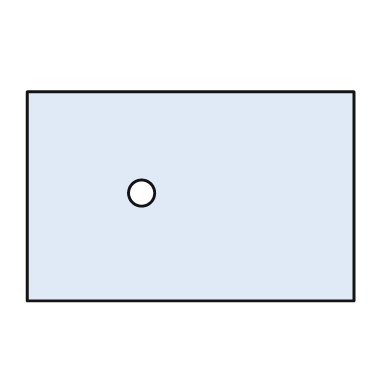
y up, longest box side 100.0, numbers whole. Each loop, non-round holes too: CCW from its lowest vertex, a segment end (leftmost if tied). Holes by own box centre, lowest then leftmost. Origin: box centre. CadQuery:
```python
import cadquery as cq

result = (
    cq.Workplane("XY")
    .moveTo(-50.0, -32.0)
    .lineTo(50.0, -32.0)
    .lineTo(50.0, 32.0)
    .lineTo(-50.0, 32.0)
    .close()
    .moveTo(-15.0, 1.0)
    .circle(4.0)
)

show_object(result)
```